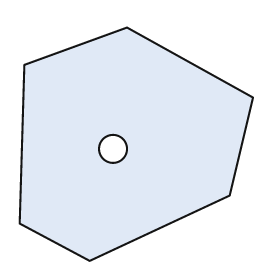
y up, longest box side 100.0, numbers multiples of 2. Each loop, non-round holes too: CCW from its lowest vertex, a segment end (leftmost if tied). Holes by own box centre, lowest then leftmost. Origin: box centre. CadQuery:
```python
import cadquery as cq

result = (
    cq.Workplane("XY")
    .moveTo(-20.0, -50.0)
    .lineTo(40.0, -22.0)
    .lineTo(50.0, 20.0)
    .lineTo(-4.0, 50.0)
    .lineTo(-48.0, 34.0)
    .lineTo(-50.0, -34.0)
    .close()
    .moveTo(-10.0, -2.0)
    .circle(6.0)
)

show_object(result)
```